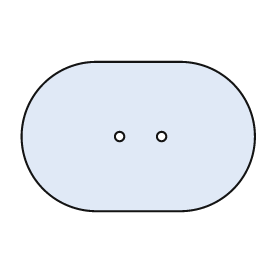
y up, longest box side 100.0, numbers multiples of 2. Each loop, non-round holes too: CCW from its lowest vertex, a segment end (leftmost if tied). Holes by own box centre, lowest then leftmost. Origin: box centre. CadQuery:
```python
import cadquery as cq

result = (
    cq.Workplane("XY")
    .moveTo(-18.0, -32.0)
    .lineTo(18.0, -32.0)
    .threePointArc((50.0, 0.0), (18.0, 32.0))
    .lineTo(-18.0, 32.0)
    .threePointArc((-50.0, 0.0), (-18.0, -32.0))
    .close()
    .moveTo(-8.0, 0.0)
    .circle(2.0)
    .moveTo(10.0, 0.0)
    .circle(2.0)
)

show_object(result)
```